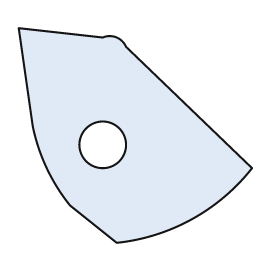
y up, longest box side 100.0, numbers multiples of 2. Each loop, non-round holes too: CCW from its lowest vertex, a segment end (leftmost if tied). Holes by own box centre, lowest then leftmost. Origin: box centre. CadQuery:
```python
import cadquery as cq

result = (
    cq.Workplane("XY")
    .moveTo(-8.0, -46.0)
    .threePointArc((24.0, -36.0), (50.0, -14.0))
    .lineTo(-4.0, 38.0)
    .threePointArc((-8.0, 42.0), (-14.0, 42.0))
    .lineTo(-50.0, 46.0)
    .lineTo(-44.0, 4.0)
    .threePointArc((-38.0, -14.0), (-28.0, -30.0))
    .close()
    .moveTo(-14.0, -4.0)
    .circle(10.0)
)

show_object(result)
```